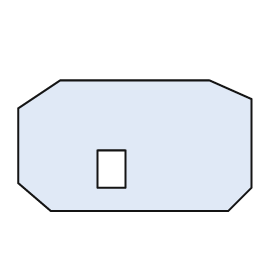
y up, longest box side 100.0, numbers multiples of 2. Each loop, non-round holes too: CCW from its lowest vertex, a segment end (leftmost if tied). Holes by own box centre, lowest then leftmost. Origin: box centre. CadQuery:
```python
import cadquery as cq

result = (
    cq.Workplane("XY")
    .moveTo(-36.0, -28.0)
    .lineTo(40.0, -28.0)
    .lineTo(50.0, -18.0)
    .lineTo(50.0, 20.0)
    .lineTo(32.0, 28.0)
    .lineTo(-32.0, 28.0)
    .lineTo(-50.0, 16.0)
    .lineTo(-50.0, -16.0)
    .close()
    .moveTo(-16.0, -18.0)
    .lineTo(-4.0, -18.0)
    .lineTo(-4.0, -2.0)
    .lineTo(-16.0, -2.0)
    .close()
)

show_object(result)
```